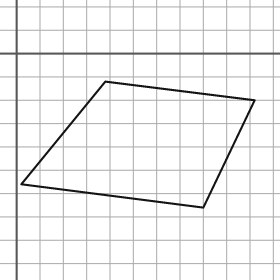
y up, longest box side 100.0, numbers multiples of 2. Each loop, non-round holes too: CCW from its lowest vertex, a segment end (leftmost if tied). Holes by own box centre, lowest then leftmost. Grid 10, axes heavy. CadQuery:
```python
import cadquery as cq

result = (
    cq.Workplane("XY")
    .moveTo(80.0, -66.0)
    .lineTo(102.0, -20.0)
    .lineTo(38.0, -12.0)
    .lineTo(2.0, -56.0)
    .close()
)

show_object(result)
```